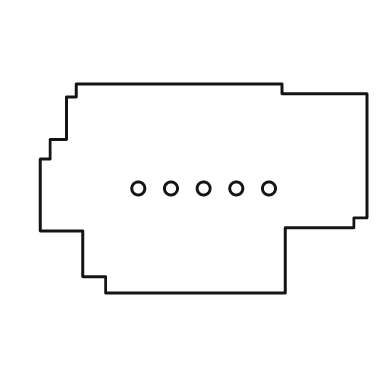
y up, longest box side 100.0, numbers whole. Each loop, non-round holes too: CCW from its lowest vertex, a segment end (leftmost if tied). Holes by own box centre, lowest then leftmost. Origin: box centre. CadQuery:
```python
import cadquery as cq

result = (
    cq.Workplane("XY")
    .moveTo(-30.0, -32.0)
    .lineTo(25.0, -32.0)
    .lineTo(25.0, -12.0)
    .lineTo(46.0, -12.0)
    .lineTo(46.0, -9.0)
    .lineTo(50.0, -9.0)
    .lineTo(50.0, 29.0)
    .lineTo(24.0, 29.0)
    .lineTo(24.0, 32.0)
    .lineTo(-39.0, 32.0)
    .lineTo(-39.0, 28.0)
    .lineTo(-42.0, 28.0)
    .lineTo(-42.0, 15.0)
    .lineTo(-47.0, 15.0)
    .lineTo(-47.0, 9.0)
    .lineTo(-50.0, 9.0)
    .lineTo(-50.0, -13.0)
    .lineTo(-37.0, -13.0)
    .lineTo(-37.0, -27.0)
    .lineTo(-30.0, -27.0)
    .close()
    .moveTo(-20.0, 0.0)
    .circle(2.0)
    .moveTo(-10.0, 0.0)
    .circle(2.0)
    .moveTo(0.0, 0.0)
    .circle(2.0)
    .moveTo(10.0, 0.0)
    .circle(2.0)
    .moveTo(20.0, 0.0)
    .circle(2.0)
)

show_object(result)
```